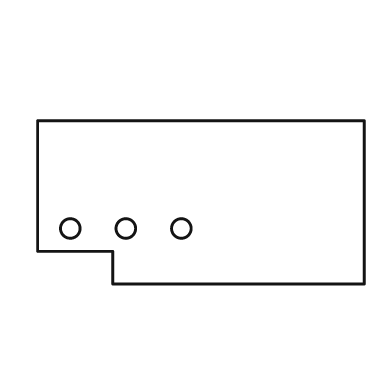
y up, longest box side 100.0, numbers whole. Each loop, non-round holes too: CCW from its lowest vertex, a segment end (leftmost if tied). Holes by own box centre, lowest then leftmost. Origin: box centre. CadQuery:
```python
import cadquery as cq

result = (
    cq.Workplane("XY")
    .moveTo(-27.0, -25.0)
    .lineTo(50.0, -25.0)
    .lineTo(50.0, 25.0)
    .lineTo(-50.0, 25.0)
    .lineTo(-50.0, -15.0)
    .lineTo(-27.0, -15.0)
    .close()
    .moveTo(-40.0, -8.0)
    .circle(3.0)
    .moveTo(-23.0, -8.0)
    .circle(3.0)
    .moveTo(-6.0, -8.0)
    .circle(3.0)
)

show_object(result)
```